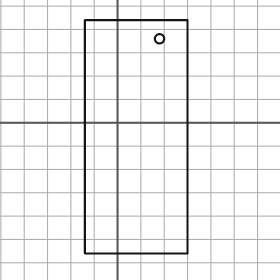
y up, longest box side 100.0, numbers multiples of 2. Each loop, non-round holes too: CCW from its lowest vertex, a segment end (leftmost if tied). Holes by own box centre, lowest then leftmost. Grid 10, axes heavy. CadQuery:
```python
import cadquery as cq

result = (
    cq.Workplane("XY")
    .moveTo(-14.0, -56.0)
    .lineTo(30.0, -56.0)
    .lineTo(30.0, 44.0)
    .lineTo(-14.0, 44.0)
    .close()
    .moveTo(18.0, 36.0)
    .circle(2.0)
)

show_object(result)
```